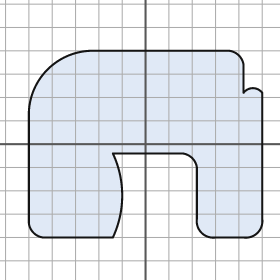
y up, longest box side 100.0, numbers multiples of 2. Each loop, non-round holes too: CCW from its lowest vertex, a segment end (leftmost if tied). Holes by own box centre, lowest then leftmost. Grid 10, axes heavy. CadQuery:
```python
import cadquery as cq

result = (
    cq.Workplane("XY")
    .moveTo(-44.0, -40.0)
    .lineTo(-14.0, -40.0)
    .threePointArc((-10.0, -22.0), (-14.0, -4.0))
    .lineTo(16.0, -4.0)
    .threePointArc((20.0, -6.0), (22.0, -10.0))
    .lineTo(22.0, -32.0)
    .threePointArc((24.0, -38.0), (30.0, -40.0))
    .lineTo(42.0, -40.0)
    .threePointArc((48.0, -38.0), (50.0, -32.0))
    .lineTo(50.0, 22.0)
    .threePointArc((46.0, 24.0), (42.0, 22.0))
    .lineTo(42.0, 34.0)
    .threePointArc((40.0, 38.0), (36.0, 40.0))
    .lineTo(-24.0, 40.0)
    .threePointArc((-42.0, 32.0), (-50.0, 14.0))
    .lineTo(-50.0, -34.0)
    .threePointArc((-48.0, -38.0), (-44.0, -40.0))
    .close()
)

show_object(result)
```